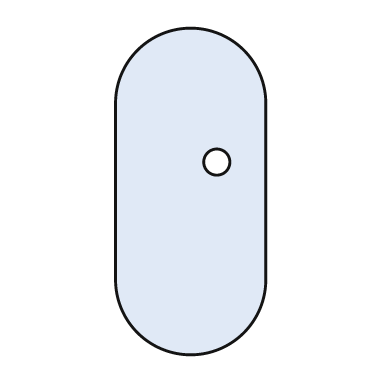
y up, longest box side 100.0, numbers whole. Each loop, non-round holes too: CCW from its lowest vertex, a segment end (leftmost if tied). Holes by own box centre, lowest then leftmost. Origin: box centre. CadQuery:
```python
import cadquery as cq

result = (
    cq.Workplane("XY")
    .moveTo(-23.0, -27.0)
    .threePointArc((0.0, -50.0), (23.0, -27.0))
    .lineTo(23.0, 27.0)
    .threePointArc((0.0, 50.0), (-23.0, 27.0))
    .close()
    .moveTo(8.0, 9.0)
    .circle(4.0)
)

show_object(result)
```